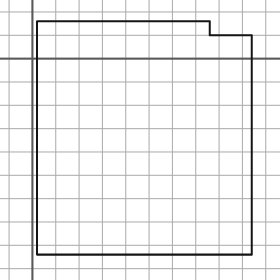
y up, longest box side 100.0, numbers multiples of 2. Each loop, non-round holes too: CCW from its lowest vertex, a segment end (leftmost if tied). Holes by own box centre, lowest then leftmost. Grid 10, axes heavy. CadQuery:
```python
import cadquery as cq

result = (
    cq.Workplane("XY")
    .moveTo(2.0, -84.0)
    .lineTo(94.0, -84.0)
    .lineTo(94.0, 10.0)
    .lineTo(76.0, 10.0)
    .lineTo(76.0, 16.0)
    .lineTo(2.0, 16.0)
    .close()
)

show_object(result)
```